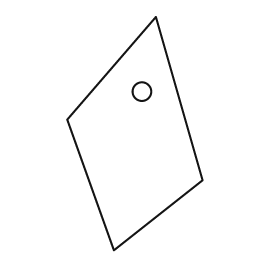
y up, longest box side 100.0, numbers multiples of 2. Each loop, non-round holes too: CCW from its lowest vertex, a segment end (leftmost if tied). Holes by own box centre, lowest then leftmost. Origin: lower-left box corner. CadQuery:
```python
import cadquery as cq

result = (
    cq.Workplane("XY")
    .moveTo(20.0, 0.0)
    .lineTo(58.0, 30.0)
    .lineTo(38.0, 100.0)
    .lineTo(0.0, 56.0)
    .close()
    .moveTo(32.0, 68.0)
    .circle(4.0)
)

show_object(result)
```